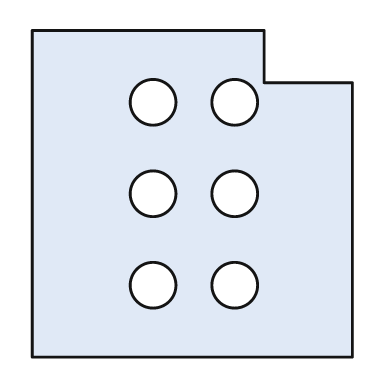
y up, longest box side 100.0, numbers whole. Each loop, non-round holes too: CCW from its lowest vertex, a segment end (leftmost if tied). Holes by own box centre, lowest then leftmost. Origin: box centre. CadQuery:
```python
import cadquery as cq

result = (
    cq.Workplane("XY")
    .moveTo(-49.0, -50.0)
    .lineTo(49.0, -50.0)
    .lineTo(49.0, 34.0)
    .lineTo(22.0, 34.0)
    .lineTo(22.0, 50.0)
    .lineTo(-49.0, 50.0)
    .close()
    .moveTo(-12.0, -28.0)
    .circle(7.0)
    .moveTo(13.0, -28.0)
    .circle(7.0)
    .moveTo(-12.0, 0.0)
    .circle(7.0)
    .moveTo(13.0, 0.0)
    .circle(7.0)
    .moveTo(-12.0, 28.0)
    .circle(7.0)
    .moveTo(13.0, 28.0)
    .circle(7.0)
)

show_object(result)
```